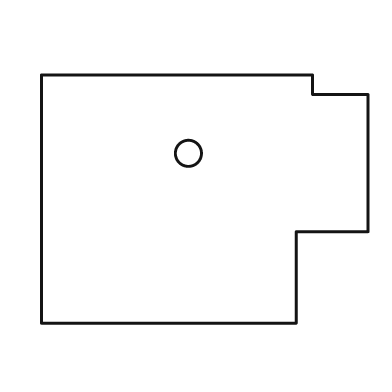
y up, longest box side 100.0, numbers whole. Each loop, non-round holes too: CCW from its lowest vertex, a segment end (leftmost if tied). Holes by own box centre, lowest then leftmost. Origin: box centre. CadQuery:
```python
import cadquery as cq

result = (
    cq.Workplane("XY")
    .moveTo(-50.0, -38.0)
    .lineTo(28.0, -38.0)
    .lineTo(28.0, -10.0)
    .lineTo(50.0, -10.0)
    .lineTo(50.0, 32.0)
    .lineTo(33.0, 32.0)
    .lineTo(33.0, 38.0)
    .lineTo(-50.0, 38.0)
    .close()
    .moveTo(-5.0, 14.0)
    .circle(4.0)
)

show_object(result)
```